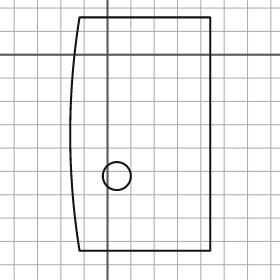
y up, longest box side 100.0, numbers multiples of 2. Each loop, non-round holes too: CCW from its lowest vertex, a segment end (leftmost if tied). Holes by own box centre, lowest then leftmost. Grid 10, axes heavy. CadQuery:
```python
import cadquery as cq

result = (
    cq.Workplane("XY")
    .moveTo(-12.0, -84.0)
    .lineTo(44.0, -84.0)
    .lineTo(44.0, 16.0)
    .lineTo(-12.0, 16.0)
    .threePointArc((-16.0, -34.0), (-12.0, -84.0))
    .close()
    .moveTo(4.0, -52.0)
    .circle(6.0)
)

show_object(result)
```